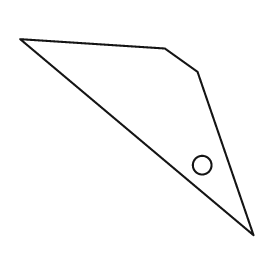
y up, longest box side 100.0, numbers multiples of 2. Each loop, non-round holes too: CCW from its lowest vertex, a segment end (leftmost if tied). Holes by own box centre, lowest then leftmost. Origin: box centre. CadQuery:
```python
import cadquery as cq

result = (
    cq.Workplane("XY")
    .moveTo(50.0, -42.0)
    .lineTo(26.0, 28.0)
    .lineTo(12.0, 38.0)
    .lineTo(-50.0, 42.0)
    .close()
    .moveTo(28.0, -12.0)
    .circle(4.0)
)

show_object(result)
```